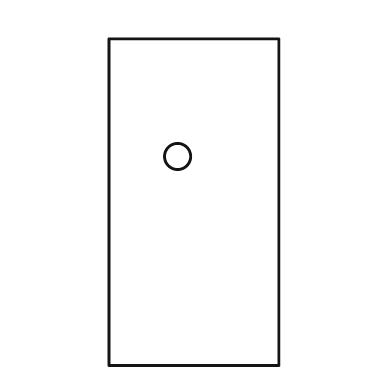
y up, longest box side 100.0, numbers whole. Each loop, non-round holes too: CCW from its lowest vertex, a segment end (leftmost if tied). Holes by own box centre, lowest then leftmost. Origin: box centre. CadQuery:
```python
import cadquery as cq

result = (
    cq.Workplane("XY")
    .moveTo(-26.0, -50.0)
    .lineTo(26.0, -50.0)
    .lineTo(26.0, 50.0)
    .lineTo(-26.0, 50.0)
    .close()
    .moveTo(-5.0, 14.0)
    .circle(4.0)
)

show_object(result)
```